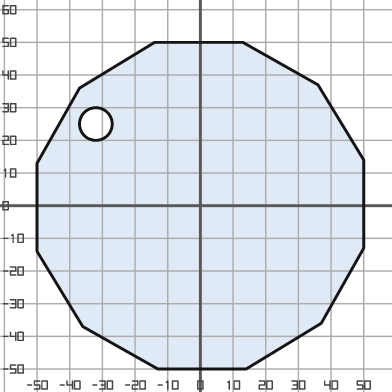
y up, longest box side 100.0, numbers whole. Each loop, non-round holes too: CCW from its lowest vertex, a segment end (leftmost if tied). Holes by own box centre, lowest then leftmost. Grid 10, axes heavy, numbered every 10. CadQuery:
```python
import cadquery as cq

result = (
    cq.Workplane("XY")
    .moveTo(-13.0, -50.0)
    .lineTo(14.0, -50.0)
    .lineTo(37.0, -36.0)
    .lineTo(50.0, -13.0)
    .lineTo(50.0, 14.0)
    .lineTo(36.0, 37.0)
    .lineTo(13.0, 50.0)
    .lineTo(-14.0, 50.0)
    .lineTo(-37.0, 36.0)
    .lineTo(-50.0, 13.0)
    .lineTo(-50.0, -14.0)
    .lineTo(-36.0, -37.0)
    .close()
    .moveTo(-32.0, 25.0)
    .circle(5.0)
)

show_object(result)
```